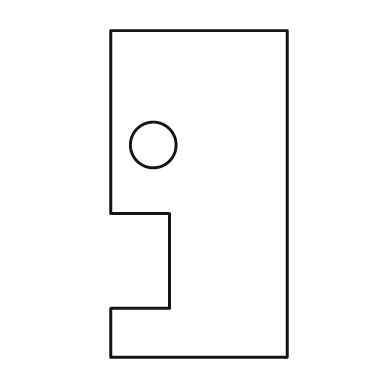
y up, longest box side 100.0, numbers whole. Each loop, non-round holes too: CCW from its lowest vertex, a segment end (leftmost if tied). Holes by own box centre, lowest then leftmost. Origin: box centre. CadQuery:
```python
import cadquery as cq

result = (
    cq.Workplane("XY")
    .moveTo(-27.0, -50.0)
    .lineTo(27.0, -50.0)
    .lineTo(27.0, 50.0)
    .lineTo(-27.0, 50.0)
    .lineTo(-27.0, -6.0)
    .lineTo(-9.0, -6.0)
    .lineTo(-9.0, -35.0)
    .lineTo(-27.0, -35.0)
    .close()
    .moveTo(-14.0, 15.0)
    .circle(7.0)
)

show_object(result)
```